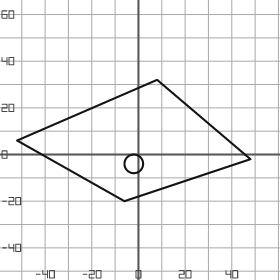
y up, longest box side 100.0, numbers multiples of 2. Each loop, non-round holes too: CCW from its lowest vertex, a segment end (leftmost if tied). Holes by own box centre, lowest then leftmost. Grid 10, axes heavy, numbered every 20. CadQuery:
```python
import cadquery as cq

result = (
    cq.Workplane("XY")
    .moveTo(-6.0, -20.0)
    .lineTo(48.0, -2.0)
    .lineTo(8.0, 32.0)
    .lineTo(-52.0, 6.0)
    .close()
    .moveTo(-2.0, -4.0)
    .circle(4.0)
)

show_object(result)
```